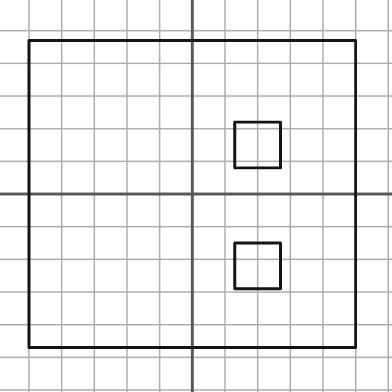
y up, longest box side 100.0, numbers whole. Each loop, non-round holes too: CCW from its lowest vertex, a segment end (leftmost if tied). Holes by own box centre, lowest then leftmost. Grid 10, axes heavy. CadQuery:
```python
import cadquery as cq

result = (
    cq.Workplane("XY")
    .moveTo(-50.0, -47.0)
    .lineTo(50.0, -47.0)
    .lineTo(50.0, 47.0)
    .lineTo(-50.0, 47.0)
    .close()
    .moveTo(13.0, -29.0)
    .lineTo(27.0, -29.0)
    .lineTo(27.0, -15.0)
    .lineTo(13.0, -15.0)
    .close()
    .moveTo(13.0, 8.0)
    .lineTo(27.0, 8.0)
    .lineTo(27.0, 22.0)
    .lineTo(13.0, 22.0)
    .close()
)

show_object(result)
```